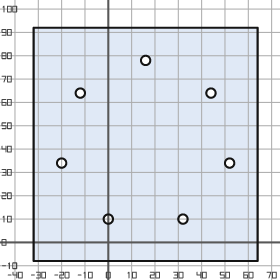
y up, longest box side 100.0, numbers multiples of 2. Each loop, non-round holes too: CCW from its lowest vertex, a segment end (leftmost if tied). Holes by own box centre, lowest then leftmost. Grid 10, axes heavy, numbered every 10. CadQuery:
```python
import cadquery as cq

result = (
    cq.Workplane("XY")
    .moveTo(-32.0, -8.0)
    .lineTo(64.0, -8.0)
    .lineTo(64.0, 92.0)
    .lineTo(-32.0, 92.0)
    .close()
    .moveTo(0.0, 10.0)
    .circle(2.0)
    .moveTo(32.0, 10.0)
    .circle(2.0)
    .moveTo(-20.0, 34.0)
    .circle(2.0)
    .moveTo(52.0, 34.0)
    .circle(2.0)
    .moveTo(-12.0, 64.0)
    .circle(2.0)
    .moveTo(44.0, 64.0)
    .circle(2.0)
    .moveTo(16.0, 78.0)
    .circle(2.0)
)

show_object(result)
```